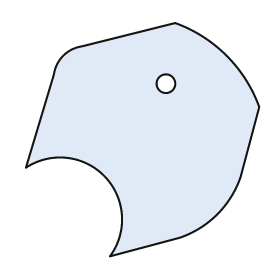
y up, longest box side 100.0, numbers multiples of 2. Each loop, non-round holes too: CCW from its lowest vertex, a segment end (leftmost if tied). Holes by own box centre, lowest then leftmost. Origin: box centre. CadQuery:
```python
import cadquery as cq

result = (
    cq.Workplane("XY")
    .moveTo(-14.0, -50.0)
    .lineTo(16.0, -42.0)
    .threePointArc((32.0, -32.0), (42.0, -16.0))
    .lineTo(50.0, 14.0)
    .threePointArc((36.0, 36.0), (14.0, 50.0))
    .lineTo(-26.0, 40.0)
    .threePointArc((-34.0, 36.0), (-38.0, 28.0))
    .lineTo(-50.0, -12.0)
    .threePointArc((-16.0, -16.0), (-14.0, -50.0))
    .close()
    .moveTo(10.0, 24.0)
    .circle(4.0)
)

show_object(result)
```